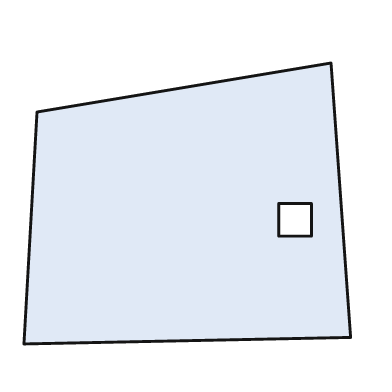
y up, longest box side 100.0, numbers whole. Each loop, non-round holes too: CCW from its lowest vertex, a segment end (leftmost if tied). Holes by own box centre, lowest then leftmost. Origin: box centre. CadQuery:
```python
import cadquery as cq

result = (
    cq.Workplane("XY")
    .moveTo(-50.0, -43.0)
    .lineTo(50.0, -41.0)
    .lineTo(44.0, 43.0)
    .lineTo(-46.0, 28.0)
    .close()
    .moveTo(28.0, -10.0)
    .lineTo(38.0, -10.0)
    .lineTo(38.0, 0.0)
    .lineTo(28.0, 0.0)
    .close()
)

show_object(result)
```